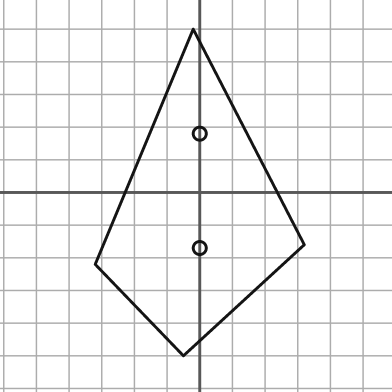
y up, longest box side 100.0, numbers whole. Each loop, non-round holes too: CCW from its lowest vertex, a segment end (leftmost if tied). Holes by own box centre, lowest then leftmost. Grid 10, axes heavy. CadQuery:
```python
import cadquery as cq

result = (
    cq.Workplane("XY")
    .moveTo(-5.0, -50.0)
    .lineTo(32.0, -16.0)
    .lineTo(-2.0, 50.0)
    .lineTo(-32.0, -22.0)
    .close()
    .moveTo(0.0, -17.0)
    .circle(2.0)
    .moveTo(0.0, 18.0)
    .circle(2.0)
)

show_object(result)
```